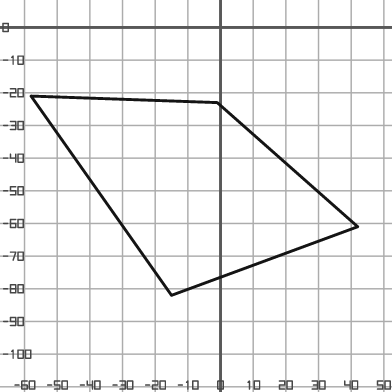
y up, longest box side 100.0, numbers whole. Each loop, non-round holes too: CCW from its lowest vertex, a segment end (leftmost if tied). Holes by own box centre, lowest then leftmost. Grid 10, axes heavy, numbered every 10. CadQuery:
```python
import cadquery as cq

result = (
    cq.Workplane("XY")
    .moveTo(-15.0, -82.0)
    .lineTo(42.0, -61.0)
    .lineTo(-1.0, -23.0)
    .lineTo(-58.0, -21.0)
    .close()
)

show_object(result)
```